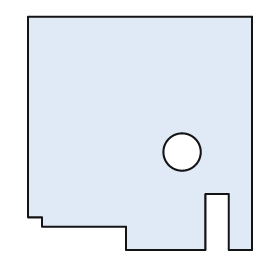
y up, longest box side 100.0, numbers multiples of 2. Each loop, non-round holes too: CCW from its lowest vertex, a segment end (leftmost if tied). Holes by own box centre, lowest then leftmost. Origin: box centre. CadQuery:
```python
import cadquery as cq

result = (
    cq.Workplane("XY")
    .moveTo(-6.0, -50.0)
    .lineTo(28.0, -50.0)
    .lineTo(28.0, -26.0)
    .lineTo(38.0, -26.0)
    .lineTo(38.0, -50.0)
    .lineTo(48.0, -50.0)
    .lineTo(48.0, 50.0)
    .lineTo(-48.0, 50.0)
    .lineTo(-48.0, -36.0)
    .lineTo(-42.0, -36.0)
    .lineTo(-42.0, -40.0)
    .lineTo(-6.0, -40.0)
    .close()
    .moveTo(18.0, -8.0)
    .circle(8.0)
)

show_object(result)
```